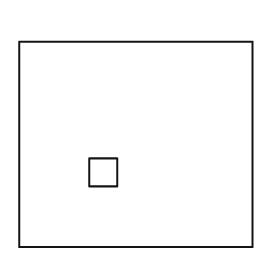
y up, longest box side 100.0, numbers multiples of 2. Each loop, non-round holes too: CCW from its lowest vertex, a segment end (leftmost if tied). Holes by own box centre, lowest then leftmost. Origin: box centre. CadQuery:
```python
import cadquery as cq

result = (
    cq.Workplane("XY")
    .moveTo(-50.0, -44.0)
    .lineTo(50.0, -44.0)
    .lineTo(50.0, 44.0)
    .lineTo(-50.0, 44.0)
    .close()
    .moveTo(-20.0, -18.0)
    .lineTo(-8.0, -18.0)
    .lineTo(-8.0, -6.0)
    .lineTo(-20.0, -6.0)
    .close()
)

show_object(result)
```